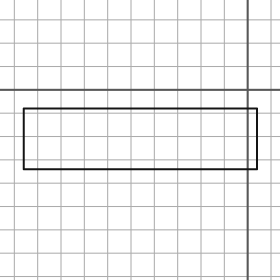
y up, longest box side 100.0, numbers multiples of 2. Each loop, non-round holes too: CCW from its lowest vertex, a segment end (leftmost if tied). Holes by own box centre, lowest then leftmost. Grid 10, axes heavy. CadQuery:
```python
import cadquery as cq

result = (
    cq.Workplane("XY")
    .moveTo(-96.0, -34.0)
    .lineTo(4.0, -34.0)
    .lineTo(4.0, -8.0)
    .lineTo(-96.0, -8.0)
    .close()
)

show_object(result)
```